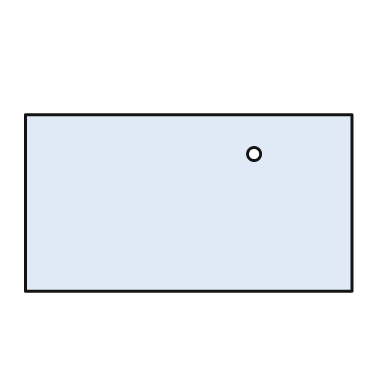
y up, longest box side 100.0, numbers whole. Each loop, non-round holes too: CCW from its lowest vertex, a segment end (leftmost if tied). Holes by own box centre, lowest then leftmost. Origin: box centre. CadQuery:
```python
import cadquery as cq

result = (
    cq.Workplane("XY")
    .moveTo(-50.0, -27.0)
    .lineTo(50.0, -27.0)
    .lineTo(50.0, 27.0)
    .lineTo(-50.0, 27.0)
    .close()
    .moveTo(20.0, 15.0)
    .circle(2.0)
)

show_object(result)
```